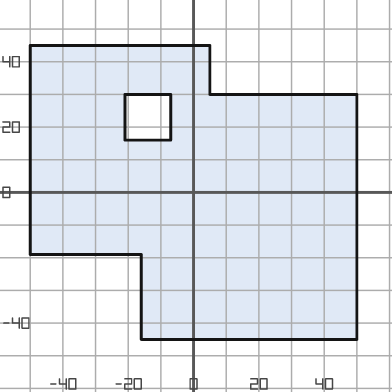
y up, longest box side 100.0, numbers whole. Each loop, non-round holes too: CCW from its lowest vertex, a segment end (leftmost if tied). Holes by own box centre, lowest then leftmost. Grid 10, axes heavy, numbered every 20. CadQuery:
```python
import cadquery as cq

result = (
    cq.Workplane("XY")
    .moveTo(-16.0, -45.0)
    .lineTo(50.0, -45.0)
    .lineTo(50.0, 30.0)
    .lineTo(5.0, 30.0)
    .lineTo(5.0, 45.0)
    .lineTo(-50.0, 45.0)
    .lineTo(-50.0, -19.0)
    .lineTo(-16.0, -19.0)
    .close()
    .moveTo(-21.0, 16.0)
    .lineTo(-7.0, 16.0)
    .lineTo(-7.0, 30.0)
    .lineTo(-21.0, 30.0)
    .close()
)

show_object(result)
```